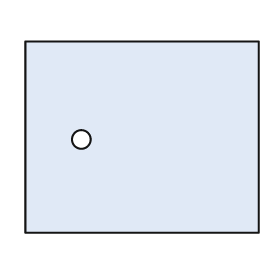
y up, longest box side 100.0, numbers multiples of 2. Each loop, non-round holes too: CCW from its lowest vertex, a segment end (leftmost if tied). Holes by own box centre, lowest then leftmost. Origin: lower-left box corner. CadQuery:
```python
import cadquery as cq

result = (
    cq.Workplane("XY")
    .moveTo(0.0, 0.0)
    .lineTo(100.0, 0.0)
    .lineTo(100.0, 82.0)
    .lineTo(0.0, 82.0)
    .close()
    .moveTo(24.0, 40.0)
    .circle(4.0)
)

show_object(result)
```